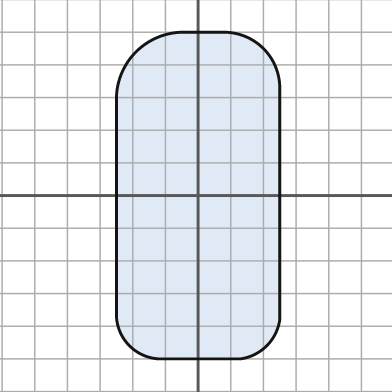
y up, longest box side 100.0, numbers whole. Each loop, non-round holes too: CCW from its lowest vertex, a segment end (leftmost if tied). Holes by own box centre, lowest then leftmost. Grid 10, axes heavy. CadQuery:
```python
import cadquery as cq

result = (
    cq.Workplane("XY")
    .moveTo(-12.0, -50.0)
    .lineTo(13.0, -50.0)
    .threePointArc((21.0, -46.0), (25.0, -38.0))
    .lineTo(25.0, 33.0)
    .threePointArc((20.0, 45.0), (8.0, 50.0))
    .lineTo(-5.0, 50.0)
    .threePointArc((-19.0, 44.0), (-25.0, 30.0))
    .lineTo(-25.0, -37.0)
    .threePointArc((-21.0, -46.0), (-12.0, -50.0))
    .close()
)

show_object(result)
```